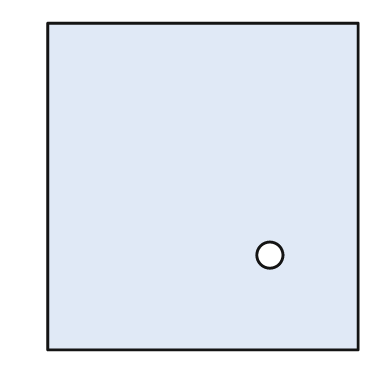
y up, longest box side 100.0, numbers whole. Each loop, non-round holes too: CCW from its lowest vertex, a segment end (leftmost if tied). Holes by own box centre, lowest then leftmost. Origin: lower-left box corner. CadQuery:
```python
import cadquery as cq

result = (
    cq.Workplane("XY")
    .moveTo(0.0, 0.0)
    .lineTo(95.0, 0.0)
    .lineTo(95.0, 100.0)
    .lineTo(0.0, 100.0)
    .close()
    .moveTo(68.0, 29.0)
    .circle(4.0)
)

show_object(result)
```